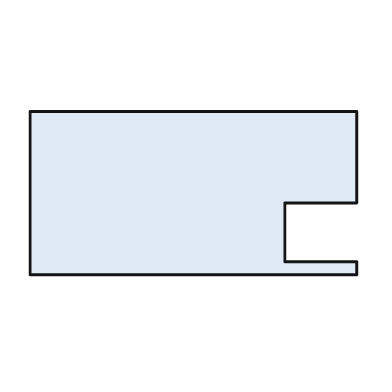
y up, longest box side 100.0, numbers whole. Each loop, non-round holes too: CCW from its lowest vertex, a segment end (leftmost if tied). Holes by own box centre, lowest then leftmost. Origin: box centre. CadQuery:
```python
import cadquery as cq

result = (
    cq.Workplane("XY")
    .moveTo(-50.0, -25.0)
    .lineTo(50.0, -25.0)
    .lineTo(50.0, -21.0)
    .lineTo(28.0, -21.0)
    .lineTo(28.0, -3.0)
    .lineTo(50.0, -3.0)
    .lineTo(50.0, 25.0)
    .lineTo(-50.0, 25.0)
    .close()
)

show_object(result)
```